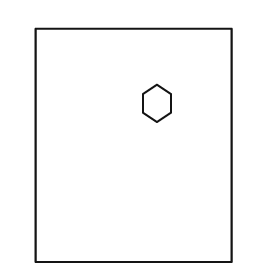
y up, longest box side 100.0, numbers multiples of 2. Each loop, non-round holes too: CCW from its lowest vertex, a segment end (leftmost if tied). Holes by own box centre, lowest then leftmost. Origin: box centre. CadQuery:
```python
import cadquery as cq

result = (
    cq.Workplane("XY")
    .moveTo(-42.0, -50.0)
    .lineTo(42.0, -50.0)
    .lineTo(42.0, 50.0)
    .lineTo(-42.0, 50.0)
    .close()
    .moveTo(10.0, 10.0)
    .lineTo(16.0, 14.0)
    .lineTo(16.0, 22.0)
    .lineTo(10.0, 26.0)
    .lineTo(4.0, 22.0)
    .lineTo(4.0, 14.0)
    .close()
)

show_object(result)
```